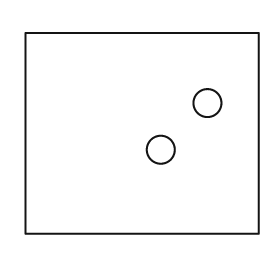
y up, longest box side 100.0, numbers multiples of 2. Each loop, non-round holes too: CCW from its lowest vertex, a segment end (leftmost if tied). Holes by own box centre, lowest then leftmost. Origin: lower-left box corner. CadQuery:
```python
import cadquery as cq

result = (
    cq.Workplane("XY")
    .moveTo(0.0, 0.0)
    .lineTo(100.0, 0.0)
    .lineTo(100.0, 86.0)
    .lineTo(0.0, 86.0)
    .close()
    .moveTo(58.0, 36.0)
    .circle(6.0)
    .moveTo(78.0, 56.0)
    .circle(6.0)
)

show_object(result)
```